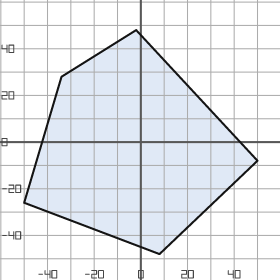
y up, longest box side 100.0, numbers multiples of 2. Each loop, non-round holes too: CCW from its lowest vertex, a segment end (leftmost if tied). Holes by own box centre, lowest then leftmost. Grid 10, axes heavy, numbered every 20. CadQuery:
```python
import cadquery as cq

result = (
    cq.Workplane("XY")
    .moveTo(8.0, -48.0)
    .lineTo(50.0, -8.0)
    .lineTo(-2.0, 48.0)
    .lineTo(-34.0, 28.0)
    .lineTo(-50.0, -26.0)
    .close()
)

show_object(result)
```